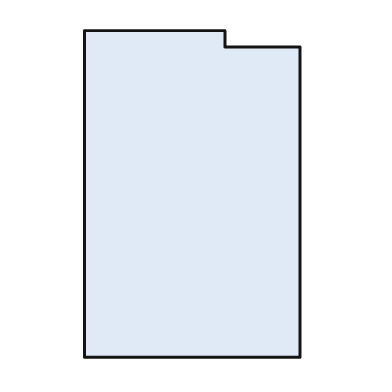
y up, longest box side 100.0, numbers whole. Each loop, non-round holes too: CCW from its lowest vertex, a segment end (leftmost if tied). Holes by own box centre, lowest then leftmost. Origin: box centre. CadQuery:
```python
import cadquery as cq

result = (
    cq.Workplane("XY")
    .moveTo(-33.0, -50.0)
    .lineTo(33.0, -50.0)
    .lineTo(33.0, 45.0)
    .lineTo(10.0, 45.0)
    .lineTo(10.0, 50.0)
    .lineTo(-33.0, 50.0)
    .close()
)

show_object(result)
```